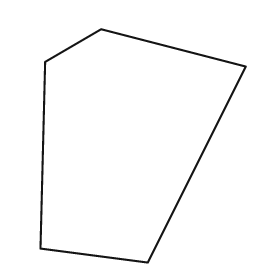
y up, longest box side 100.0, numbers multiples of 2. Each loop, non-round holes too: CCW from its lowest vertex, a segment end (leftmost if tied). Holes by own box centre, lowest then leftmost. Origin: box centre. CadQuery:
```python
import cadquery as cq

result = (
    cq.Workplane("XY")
    .moveTo(2.0, -50.0)
    .lineTo(44.0, 34.0)
    .lineTo(-18.0, 50.0)
    .lineTo(-42.0, 36.0)
    .lineTo(-44.0, -44.0)
    .close()
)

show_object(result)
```